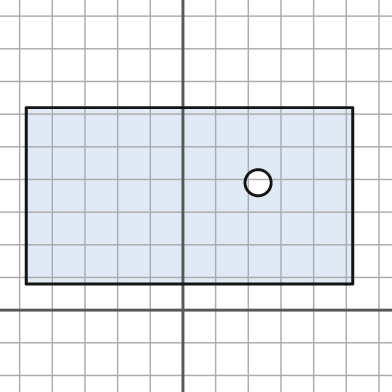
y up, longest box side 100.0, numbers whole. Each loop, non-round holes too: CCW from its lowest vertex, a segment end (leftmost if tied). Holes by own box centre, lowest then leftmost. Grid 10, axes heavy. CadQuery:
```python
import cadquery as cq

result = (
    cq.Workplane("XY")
    .moveTo(-48.0, 8.0)
    .lineTo(52.0, 8.0)
    .lineTo(52.0, 62.0)
    .lineTo(-48.0, 62.0)
    .close()
    .moveTo(23.0, 39.0)
    .circle(4.0)
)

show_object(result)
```